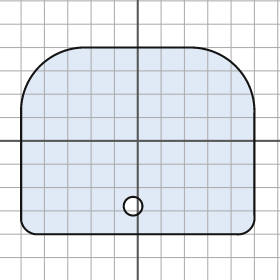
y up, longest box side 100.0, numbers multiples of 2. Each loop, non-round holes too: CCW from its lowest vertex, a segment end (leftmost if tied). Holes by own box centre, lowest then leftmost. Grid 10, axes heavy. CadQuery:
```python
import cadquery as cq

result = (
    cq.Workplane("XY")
    .moveTo(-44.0, -40.0)
    .lineTo(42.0, -40.0)
    .threePointArc((48.0, -38.0), (50.0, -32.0))
    .lineTo(50.0, 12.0)
    .threePointArc((42.0, 32.0), (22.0, 40.0))
    .lineTo(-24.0, 40.0)
    .threePointArc((-42.0, 32.0), (-50.0, 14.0))
    .lineTo(-50.0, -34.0)
    .threePointArc((-48.0, -38.0), (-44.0, -40.0))
    .close()
    .moveTo(-2.0, -28.0)
    .circle(4.0)
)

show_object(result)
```